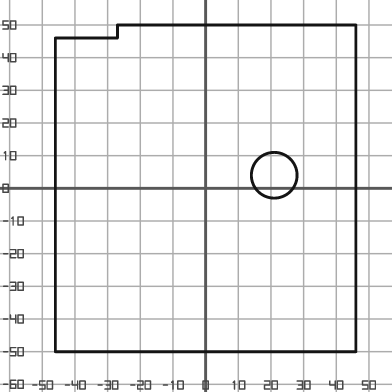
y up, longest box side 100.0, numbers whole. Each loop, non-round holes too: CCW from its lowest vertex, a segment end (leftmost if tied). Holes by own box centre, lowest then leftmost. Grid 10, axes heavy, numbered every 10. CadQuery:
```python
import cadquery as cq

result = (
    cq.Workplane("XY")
    .moveTo(-46.0, -50.0)
    .lineTo(46.0, -50.0)
    .lineTo(46.0, 50.0)
    .lineTo(-27.0, 50.0)
    .lineTo(-27.0, 46.0)
    .lineTo(-46.0, 46.0)
    .close()
    .moveTo(21.0, 4.0)
    .circle(7.0)
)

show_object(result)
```